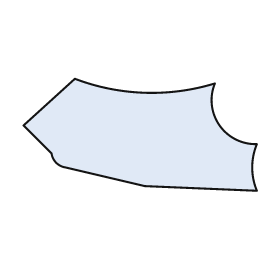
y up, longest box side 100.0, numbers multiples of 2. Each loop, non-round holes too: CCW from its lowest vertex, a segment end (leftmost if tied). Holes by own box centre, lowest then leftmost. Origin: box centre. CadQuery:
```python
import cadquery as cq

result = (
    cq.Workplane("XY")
    .moveTo(50.0, -24.0)
    .threePointArc((48.0, -14.0), (50.0, -4.0))
    .threePointArc((34.0, 4.0), (32.0, 22.0))
    .threePointArc((2.0, 18.0), (-28.0, 24.0))
    .lineTo(-50.0, 4.0)
    .lineTo(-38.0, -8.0)
    .threePointArc((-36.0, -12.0), (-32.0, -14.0))
    .lineTo(2.0, -22.0)
    .close()
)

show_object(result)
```